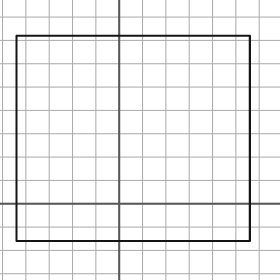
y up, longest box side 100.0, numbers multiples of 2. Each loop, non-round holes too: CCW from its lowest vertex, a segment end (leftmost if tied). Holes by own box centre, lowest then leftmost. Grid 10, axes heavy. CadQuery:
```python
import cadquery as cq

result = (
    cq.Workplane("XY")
    .moveTo(-44.0, -16.0)
    .lineTo(56.0, -16.0)
    .lineTo(56.0, 72.0)
    .lineTo(-44.0, 72.0)
    .close()
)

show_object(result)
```